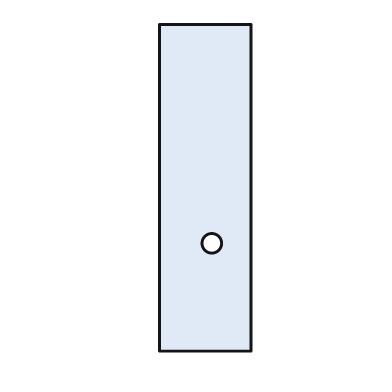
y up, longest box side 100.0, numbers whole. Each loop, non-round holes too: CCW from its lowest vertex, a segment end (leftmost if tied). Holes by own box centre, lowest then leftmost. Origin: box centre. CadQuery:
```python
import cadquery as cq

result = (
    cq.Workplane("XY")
    .moveTo(-14.0, -50.0)
    .lineTo(14.0, -50.0)
    .lineTo(14.0, 50.0)
    .lineTo(-14.0, 50.0)
    .close()
    .moveTo(2.0, -17.0)
    .circle(3.0)
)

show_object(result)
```